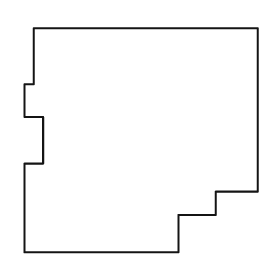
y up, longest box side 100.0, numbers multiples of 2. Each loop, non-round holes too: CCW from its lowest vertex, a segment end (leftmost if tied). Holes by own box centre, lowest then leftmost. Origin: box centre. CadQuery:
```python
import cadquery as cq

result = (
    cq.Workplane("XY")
    .moveTo(-50.0, -48.0)
    .lineTo(16.0, -48.0)
    .lineTo(16.0, -32.0)
    .lineTo(32.0, -32.0)
    .lineTo(32.0, -22.0)
    .lineTo(50.0, -22.0)
    .lineTo(50.0, 48.0)
    .lineTo(-46.0, 48.0)
    .lineTo(-46.0, 24.0)
    .lineTo(-50.0, 24.0)
    .lineTo(-50.0, 10.0)
    .lineTo(-42.0, 10.0)
    .lineTo(-42.0, -10.0)
    .lineTo(-50.0, -10.0)
    .close()
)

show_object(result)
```